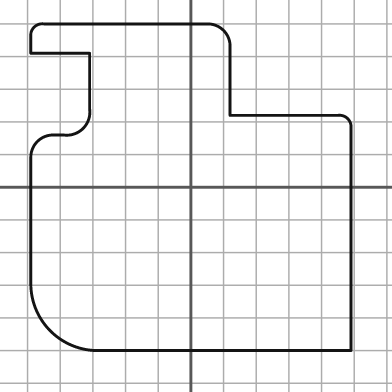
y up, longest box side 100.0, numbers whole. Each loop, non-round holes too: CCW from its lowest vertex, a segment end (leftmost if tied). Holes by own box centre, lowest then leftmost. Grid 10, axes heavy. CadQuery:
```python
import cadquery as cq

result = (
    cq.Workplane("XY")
    .moveTo(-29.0, -50.0)
    .lineTo(49.0, -50.0)
    .lineTo(49.0, 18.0)
    .threePointArc((48.0, 21.0), (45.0, 22.0))
    .lineTo(12.0, 22.0)
    .lineTo(12.0, 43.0)
    .threePointArc((10.0, 48.0), (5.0, 50.0))
    .lineTo(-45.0, 50.0)
    .threePointArc((-48.0, 49.0), (-49.0, 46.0))
    .lineTo(-49.0, 41.0)
    .lineTo(-31.0, 41.0)
    .lineTo(-31.0, 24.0)
    .threePointArc((-33.0, 18.0), (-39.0, 16.0))
    .lineTo(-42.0, 16.0)
    .threePointArc((-47.0, 14.0), (-49.0, 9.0))
    .lineTo(-49.0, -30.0)
    .threePointArc((-43.0, -44.0), (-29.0, -50.0))
    .close()
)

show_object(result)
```